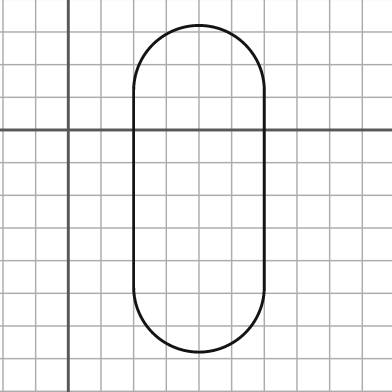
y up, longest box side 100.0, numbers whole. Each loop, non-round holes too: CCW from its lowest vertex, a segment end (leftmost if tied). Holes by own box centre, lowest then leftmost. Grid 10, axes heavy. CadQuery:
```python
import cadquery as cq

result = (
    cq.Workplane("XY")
    .moveTo(20.0, -48.0)
    .threePointArc((40.0, -68.0), (60.0, -48.0))
    .lineTo(60.0, 12.0)
    .threePointArc((40.0, 32.0), (20.0, 12.0))
    .close()
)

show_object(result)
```